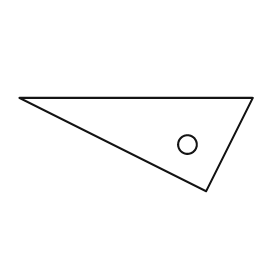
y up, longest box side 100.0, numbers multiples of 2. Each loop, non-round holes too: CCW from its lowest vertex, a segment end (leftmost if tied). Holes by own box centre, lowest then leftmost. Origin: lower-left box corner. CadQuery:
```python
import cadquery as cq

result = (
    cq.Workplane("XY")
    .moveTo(80.0, 0.0)
    .lineTo(100.0, 40.0)
    .lineTo(0.0, 40.0)
    .close()
    .moveTo(72.0, 20.0)
    .circle(4.0)
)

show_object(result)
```